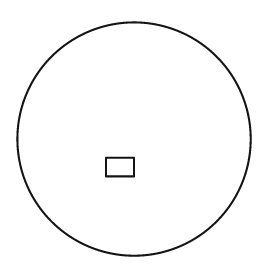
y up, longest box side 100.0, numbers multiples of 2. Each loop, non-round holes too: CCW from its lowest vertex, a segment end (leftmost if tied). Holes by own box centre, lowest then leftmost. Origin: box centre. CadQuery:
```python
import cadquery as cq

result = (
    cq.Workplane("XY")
    .moveTo(0.0, 0.0)
    .circle(50.0)
    .moveTo(-12.0, -16.0)
    .lineTo(0.0, -16.0)
    .lineTo(0.0, -8.0)
    .lineTo(-12.0, -8.0)
    .close()
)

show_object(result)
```